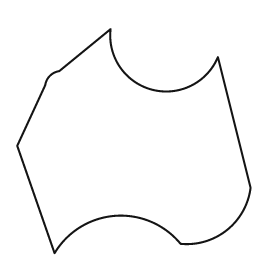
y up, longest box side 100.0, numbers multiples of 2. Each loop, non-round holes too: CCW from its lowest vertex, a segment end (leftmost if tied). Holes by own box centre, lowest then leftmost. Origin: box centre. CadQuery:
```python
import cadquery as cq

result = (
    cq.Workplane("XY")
    .moveTo(-34.0, -48.0)
    .threePointArc((-8.0, -32.0), (20.0, -44.0))
    .threePointArc((40.0, -38.0), (50.0, -20.0))
    .lineTo(36.0, 36.0)
    .threePointArc((8.0, 22.0), (-10.0, 48.0))
    .lineTo(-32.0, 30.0)
    .threePointArc((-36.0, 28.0), (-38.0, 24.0))
    .lineTo(-50.0, -2.0)
    .close()
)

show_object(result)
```